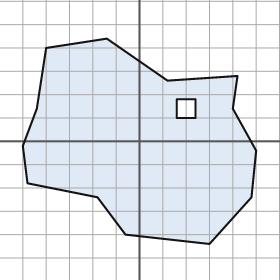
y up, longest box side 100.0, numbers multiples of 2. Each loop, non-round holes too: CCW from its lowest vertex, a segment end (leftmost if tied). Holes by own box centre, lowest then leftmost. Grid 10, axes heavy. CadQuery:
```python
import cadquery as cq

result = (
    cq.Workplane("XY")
    .moveTo(30.0, -44.0)
    .lineTo(48.0, -24.0)
    .lineTo(50.0, -4.0)
    .lineTo(40.0, 14.0)
    .lineTo(42.0, 28.0)
    .lineTo(12.0, 26.0)
    .lineTo(-14.0, 44.0)
    .lineTo(-40.0, 40.0)
    .lineTo(-44.0, 14.0)
    .lineTo(-50.0, -2.0)
    .lineTo(-48.0, -18.0)
    .lineTo(-18.0, -24.0)
    .lineTo(-6.0, -40.0)
    .close()
    .moveTo(16.0, 10.0)
    .lineTo(24.0, 10.0)
    .lineTo(24.0, 18.0)
    .lineTo(16.0, 18.0)
    .close()
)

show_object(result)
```